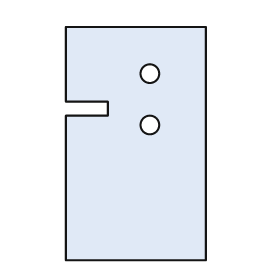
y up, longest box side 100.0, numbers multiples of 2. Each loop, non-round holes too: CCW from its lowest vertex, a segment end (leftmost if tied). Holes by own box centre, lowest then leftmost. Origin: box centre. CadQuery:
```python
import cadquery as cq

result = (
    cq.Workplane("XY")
    .moveTo(-30.0, -50.0)
    .lineTo(30.0, -50.0)
    .lineTo(30.0, 50.0)
    .lineTo(-30.0, 50.0)
    .lineTo(-30.0, 18.0)
    .lineTo(-12.0, 18.0)
    .lineTo(-12.0, 12.0)
    .lineTo(-30.0, 12.0)
    .close()
    .moveTo(6.0, 8.0)
    .circle(4.0)
    .moveTo(6.0, 30.0)
    .circle(4.0)
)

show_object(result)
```